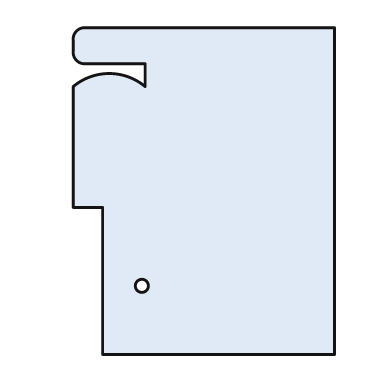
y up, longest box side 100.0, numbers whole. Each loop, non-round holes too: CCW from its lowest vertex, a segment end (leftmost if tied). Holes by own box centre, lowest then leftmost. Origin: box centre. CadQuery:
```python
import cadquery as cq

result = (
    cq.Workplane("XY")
    .moveTo(-31.0, -50.0)
    .lineTo(40.0, -50.0)
    .lineTo(40.0, 50.0)
    .lineTo(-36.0, 50.0)
    .threePointArc((-39.0, 49.0), (-40.0, 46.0))
    .lineTo(-40.0, 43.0)
    .threePointArc((-39.0, 40.0), (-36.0, 39.0))
    .lineTo(-18.0, 39.0)
    .lineTo(-18.0, 32.0)
    .threePointArc((-29.0, 36.0), (-40.0, 32.0))
    .lineTo(-40.0, -5.0)
    .lineTo(-31.0, -5.0)
    .close()
    .moveTo(-19.0, -29.0)
    .circle(2.0)
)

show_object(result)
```